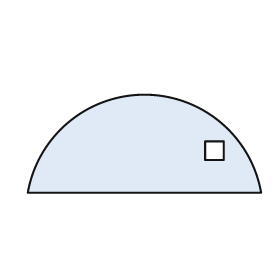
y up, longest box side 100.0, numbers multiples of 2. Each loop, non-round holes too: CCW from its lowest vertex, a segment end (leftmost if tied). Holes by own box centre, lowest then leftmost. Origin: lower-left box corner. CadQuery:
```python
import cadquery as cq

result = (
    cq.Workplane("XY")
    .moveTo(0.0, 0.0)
    .lineTo(100.0, 0.0)
    .threePointArc((50.0, 42.0), (0.0, 0.0))
    .close()
    .moveTo(76.0, 14.0)
    .lineTo(84.0, 14.0)
    .lineTo(84.0, 22.0)
    .lineTo(76.0, 22.0)
    .close()
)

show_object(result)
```